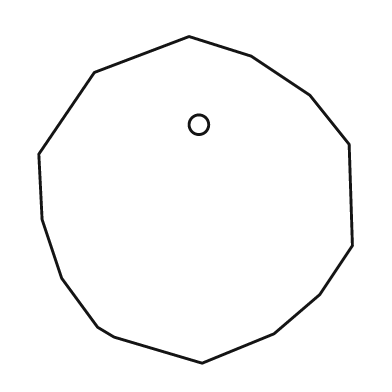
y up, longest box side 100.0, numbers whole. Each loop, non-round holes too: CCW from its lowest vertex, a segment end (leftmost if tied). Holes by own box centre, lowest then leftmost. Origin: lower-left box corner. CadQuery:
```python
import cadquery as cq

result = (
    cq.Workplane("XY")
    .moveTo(50.0, 0.0)
    .lineTo(72.0, 9.0)
    .lineTo(86.0, 21.0)
    .lineTo(96.0, 36.0)
    .lineTo(95.0, 67.0)
    .lineTo(83.0, 82.0)
    .lineTo(65.0, 94.0)
    .lineTo(46.0, 100.0)
    .lineTo(17.0, 89.0)
    .lineTo(0.0, 64.0)
    .lineTo(1.0, 44.0)
    .lineTo(7.0, 26.0)
    .lineTo(18.0, 11.0)
    .lineTo(23.0, 8.0)
    .close()
    .moveTo(49.0, 73.0)
    .circle(3.0)
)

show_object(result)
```